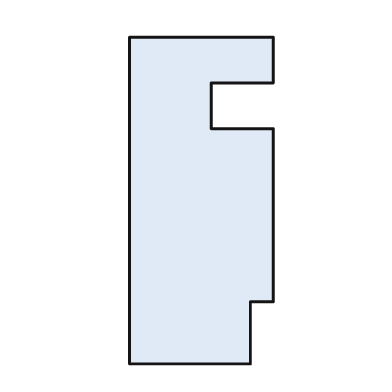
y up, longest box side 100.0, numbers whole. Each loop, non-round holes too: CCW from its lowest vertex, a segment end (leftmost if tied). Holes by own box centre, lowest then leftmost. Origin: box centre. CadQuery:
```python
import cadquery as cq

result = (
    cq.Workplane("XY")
    .moveTo(-22.0, -50.0)
    .lineTo(15.0, -50.0)
    .lineTo(15.0, -31.0)
    .lineTo(22.0, -31.0)
    .lineTo(22.0, 22.0)
    .lineTo(3.0, 22.0)
    .lineTo(3.0, 36.0)
    .lineTo(22.0, 36.0)
    .lineTo(22.0, 50.0)
    .lineTo(-22.0, 50.0)
    .close()
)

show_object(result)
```